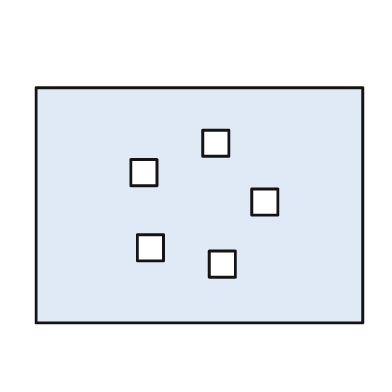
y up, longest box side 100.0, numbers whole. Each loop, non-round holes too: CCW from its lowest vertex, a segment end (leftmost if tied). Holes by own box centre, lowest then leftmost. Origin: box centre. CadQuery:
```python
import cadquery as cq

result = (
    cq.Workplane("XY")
    .moveTo(-50.0, -36.0)
    .lineTo(50.0, -36.0)
    .lineTo(50.0, 36.0)
    .lineTo(-50.0, 36.0)
    .close()
    .moveTo(3.0, -22.0)
    .lineTo(11.0, -22.0)
    .lineTo(11.0, -14.0)
    .lineTo(3.0, -14.0)
    .close()
    .moveTo(-19.0, -17.0)
    .lineTo(-11.0, -17.0)
    .lineTo(-11.0, -9.0)
    .lineTo(-19.0, -9.0)
    .close()
    .moveTo(16.0, -3.0)
    .lineTo(24.0, -3.0)
    .lineTo(24.0, 5.0)
    .lineTo(16.0, 5.0)
    .close()
    .moveTo(-21.0, 6.0)
    .lineTo(-13.0, 6.0)
    .lineTo(-13.0, 14.0)
    .lineTo(-21.0, 14.0)
    .close()
    .moveTo(1.0, 15.0)
    .lineTo(9.0, 15.0)
    .lineTo(9.0, 23.0)
    .lineTo(1.0, 23.0)
    .close()
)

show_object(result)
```